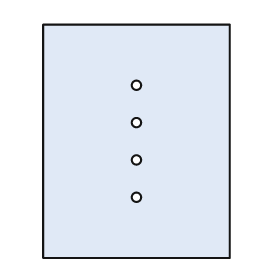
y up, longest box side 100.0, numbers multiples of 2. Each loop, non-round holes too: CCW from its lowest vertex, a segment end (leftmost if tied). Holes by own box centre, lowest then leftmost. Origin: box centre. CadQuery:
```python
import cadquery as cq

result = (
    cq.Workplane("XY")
    .moveTo(-40.0, -50.0)
    .lineTo(40.0, -50.0)
    .lineTo(40.0, 50.0)
    .lineTo(-40.0, 50.0)
    .close()
    .moveTo(0.0, -24.0)
    .circle(2.0)
    .moveTo(0.0, -8.0)
    .circle(2.0)
    .moveTo(0.0, 8.0)
    .circle(2.0)
    .moveTo(0.0, 24.0)
    .circle(2.0)
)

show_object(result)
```